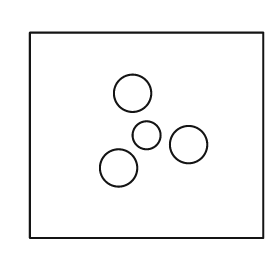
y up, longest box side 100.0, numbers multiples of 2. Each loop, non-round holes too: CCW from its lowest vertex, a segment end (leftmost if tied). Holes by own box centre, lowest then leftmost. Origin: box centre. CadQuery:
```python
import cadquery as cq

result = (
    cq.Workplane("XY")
    .moveTo(-50.0, -44.0)
    .lineTo(50.0, -44.0)
    .lineTo(50.0, 44.0)
    .lineTo(-50.0, 44.0)
    .close()
    .moveTo(-12.0, -14.0)
    .circle(8.0)
    .moveTo(18.0, -4.0)
    .circle(8.0)
    .moveTo(0.0, 0.0)
    .circle(6.0)
    .moveTo(-6.0, 18.0)
    .circle(8.0)
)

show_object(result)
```